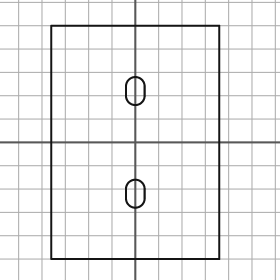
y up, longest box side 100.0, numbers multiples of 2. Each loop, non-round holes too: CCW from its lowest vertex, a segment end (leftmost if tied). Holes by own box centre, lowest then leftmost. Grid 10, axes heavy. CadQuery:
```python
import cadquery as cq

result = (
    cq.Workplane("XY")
    .moveTo(-36.0, -50.0)
    .lineTo(36.0, -50.0)
    .lineTo(36.0, 50.0)
    .lineTo(-36.0, 50.0)
    .close()
    .moveTo(-4.0, -24.0)
    .threePointArc((0.0, -28.0), (4.0, -24.0))
    .lineTo(4.0, -20.0)
    .threePointArc((0.0, -16.0), (-4.0, -20.0))
    .close()
    .moveTo(-4.0, 20.0)
    .threePointArc((0.0, 16.0), (4.0, 20.0))
    .lineTo(4.0, 24.0)
    .threePointArc((0.0, 28.0), (-4.0, 24.0))
    .close()
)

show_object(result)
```